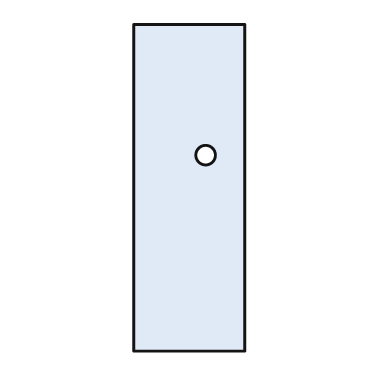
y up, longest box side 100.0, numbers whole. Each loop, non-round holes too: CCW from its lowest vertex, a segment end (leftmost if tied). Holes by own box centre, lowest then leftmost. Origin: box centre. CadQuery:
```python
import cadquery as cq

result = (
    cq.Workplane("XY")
    .moveTo(-17.0, -50.0)
    .lineTo(17.0, -50.0)
    .lineTo(17.0, 50.0)
    .lineTo(-17.0, 50.0)
    .close()
    .moveTo(5.0, 10.0)
    .circle(3.0)
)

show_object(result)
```